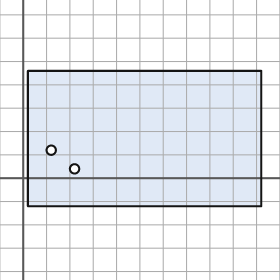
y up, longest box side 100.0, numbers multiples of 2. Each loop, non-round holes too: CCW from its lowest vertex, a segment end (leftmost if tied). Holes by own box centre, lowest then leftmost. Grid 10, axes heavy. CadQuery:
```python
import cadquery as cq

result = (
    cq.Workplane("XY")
    .moveTo(2.0, -12.0)
    .lineTo(102.0, -12.0)
    .lineTo(102.0, 46.0)
    .lineTo(2.0, 46.0)
    .close()
    .moveTo(22.0, 4.0)
    .circle(2.0)
    .moveTo(12.0, 12.0)
    .circle(2.0)
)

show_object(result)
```